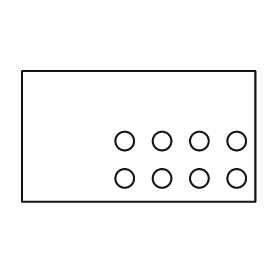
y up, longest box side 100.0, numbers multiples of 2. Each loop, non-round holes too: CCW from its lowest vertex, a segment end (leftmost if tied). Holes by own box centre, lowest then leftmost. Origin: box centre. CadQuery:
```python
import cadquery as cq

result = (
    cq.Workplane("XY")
    .moveTo(-50.0, -28.0)
    .lineTo(50.0, -28.0)
    .lineTo(50.0, 28.0)
    .lineTo(-50.0, 28.0)
    .close()
    .moveTo(-6.0, -18.0)
    .circle(4.0)
    .moveTo(10.0, -18.0)
    .circle(4.0)
    .moveTo(26.0, -18.0)
    .circle(4.0)
    .moveTo(42.0, -18.0)
    .circle(4.0)
    .moveTo(-6.0, -2.0)
    .circle(4.0)
    .moveTo(10.0, -2.0)
    .circle(4.0)
    .moveTo(26.0, -2.0)
    .circle(4.0)
    .moveTo(42.0, -2.0)
    .circle(4.0)
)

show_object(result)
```